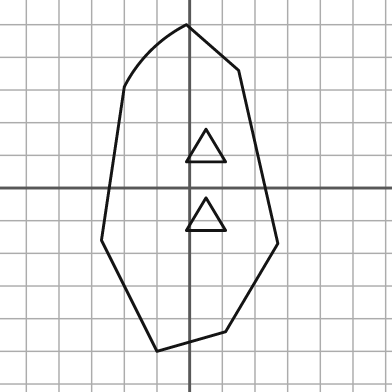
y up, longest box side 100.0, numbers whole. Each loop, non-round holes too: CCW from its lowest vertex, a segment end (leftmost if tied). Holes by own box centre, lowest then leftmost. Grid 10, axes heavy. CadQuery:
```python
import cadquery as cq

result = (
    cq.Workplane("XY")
    .moveTo(-10.0, -50.0)
    .lineTo(11.0, -44.0)
    .lineTo(27.0, -17.0)
    .lineTo(15.0, 36.0)
    .lineTo(-1.0, 50.0)
    .threePointArc((-12.0, 42.0), (-20.0, 31.0))
    .lineTo(-27.0, -16.0)
    .close()
    .moveTo(-1.0, -13.0)
    .lineTo(11.0, -13.0)
    .lineTo(5.0, -3.0)
    .close()
    .moveTo(-1.0, 8.0)
    .lineTo(11.0, 8.0)
    .lineTo(5.0, 18.0)
    .close()
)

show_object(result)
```